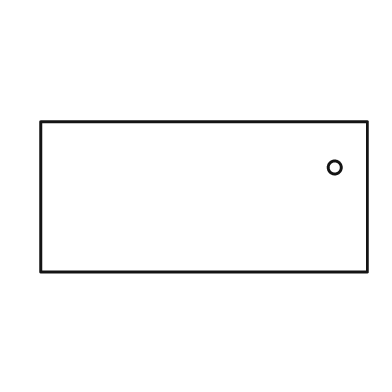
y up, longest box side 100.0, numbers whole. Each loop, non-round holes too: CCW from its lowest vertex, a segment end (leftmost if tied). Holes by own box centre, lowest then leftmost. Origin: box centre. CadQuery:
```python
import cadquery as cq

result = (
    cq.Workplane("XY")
    .moveTo(-50.0, -23.0)
    .lineTo(50.0, -23.0)
    .lineTo(50.0, 23.0)
    .lineTo(-50.0, 23.0)
    .close()
    .moveTo(40.0, 9.0)
    .circle(2.0)
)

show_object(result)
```